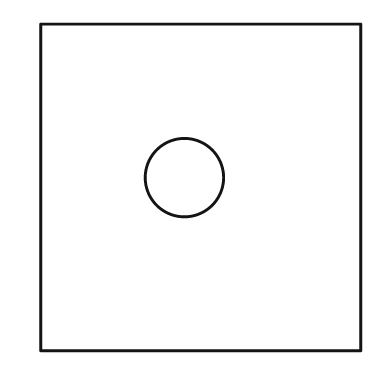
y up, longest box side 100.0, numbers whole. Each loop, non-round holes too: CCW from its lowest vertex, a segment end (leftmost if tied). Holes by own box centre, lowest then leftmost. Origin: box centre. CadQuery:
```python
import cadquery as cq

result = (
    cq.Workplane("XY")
    .moveTo(-49.0, -50.0)
    .lineTo(49.0, -50.0)
    .lineTo(49.0, 50.0)
    .lineTo(-49.0, 50.0)
    .close()
    .moveTo(-5.0, 3.0)
    .circle(12.0)
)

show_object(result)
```